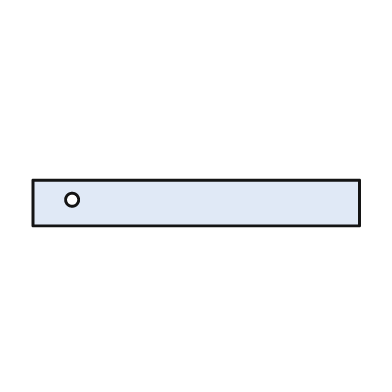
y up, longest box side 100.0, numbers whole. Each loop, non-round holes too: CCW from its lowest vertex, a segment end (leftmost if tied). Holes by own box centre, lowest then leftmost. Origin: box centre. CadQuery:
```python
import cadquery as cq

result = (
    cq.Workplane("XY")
    .moveTo(-50.0, -7.0)
    .lineTo(50.0, -7.0)
    .lineTo(50.0, 7.0)
    .lineTo(-50.0, 7.0)
    .close()
    .moveTo(-38.0, 1.0)
    .circle(2.0)
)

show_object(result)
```